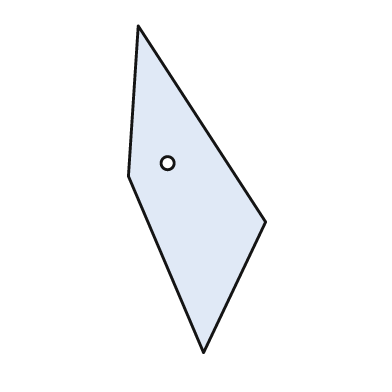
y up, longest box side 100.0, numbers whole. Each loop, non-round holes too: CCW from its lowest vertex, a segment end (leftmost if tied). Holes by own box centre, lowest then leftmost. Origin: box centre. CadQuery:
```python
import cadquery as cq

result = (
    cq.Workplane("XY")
    .moveTo(2.0, -50.0)
    .lineTo(21.0, -10.0)
    .lineTo(-18.0, 50.0)
    .lineTo(-21.0, 4.0)
    .close()
    .moveTo(-9.0, 8.0)
    .circle(2.0)
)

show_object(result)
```